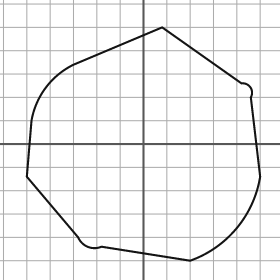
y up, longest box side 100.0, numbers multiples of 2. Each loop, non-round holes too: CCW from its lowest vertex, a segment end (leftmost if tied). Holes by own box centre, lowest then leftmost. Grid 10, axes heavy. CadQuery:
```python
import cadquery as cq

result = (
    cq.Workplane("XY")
    .moveTo(20.0, -50.0)
    .threePointArc((40.0, -36.0), (50.0, -14.0))
    .lineTo(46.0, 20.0)
    .threePointArc((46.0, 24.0), (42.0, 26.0))
    .lineTo(8.0, 50.0)
    .lineTo(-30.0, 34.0)
    .threePointArc((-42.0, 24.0), (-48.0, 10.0))
    .lineTo(-50.0, -14.0)
    .lineTo(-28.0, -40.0)
    .threePointArc((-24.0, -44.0), (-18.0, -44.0))
    .close()
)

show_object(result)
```